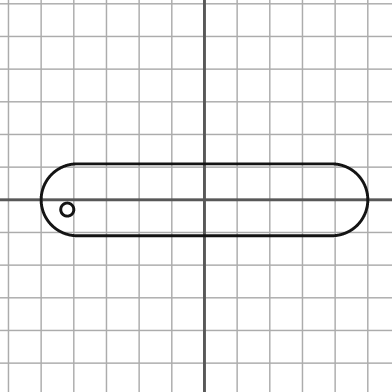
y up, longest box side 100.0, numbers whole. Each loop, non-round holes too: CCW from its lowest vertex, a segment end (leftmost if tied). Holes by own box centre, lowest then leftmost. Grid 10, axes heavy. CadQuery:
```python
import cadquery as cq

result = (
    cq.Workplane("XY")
    .moveTo(-39.0, -11.0)
    .lineTo(39.0, -11.0)
    .threePointArc((50.0, 0.0), (39.0, 11.0))
    .lineTo(-39.0, 11.0)
    .threePointArc((-50.0, 0.0), (-39.0, -11.0))
    .close()
    .moveTo(-42.0, -3.0)
    .circle(2.0)
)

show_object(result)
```